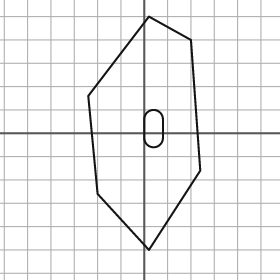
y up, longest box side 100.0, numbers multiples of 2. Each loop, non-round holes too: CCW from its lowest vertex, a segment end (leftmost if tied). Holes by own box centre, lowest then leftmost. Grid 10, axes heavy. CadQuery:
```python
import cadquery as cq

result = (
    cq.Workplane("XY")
    .moveTo(2.0, -50.0)
    .lineTo(24.0, -16.0)
    .lineTo(20.0, 40.0)
    .lineTo(2.0, 50.0)
    .lineTo(-24.0, 16.0)
    .lineTo(-20.0, -26.0)
    .close()
    .moveTo(0.0, -2.0)
    .threePointArc((4.0, -6.0), (8.0, -2.0))
    .lineTo(8.0, 6.0)
    .threePointArc((4.0, 10.0), (0.0, 6.0))
    .close()
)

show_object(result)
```